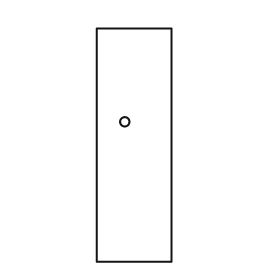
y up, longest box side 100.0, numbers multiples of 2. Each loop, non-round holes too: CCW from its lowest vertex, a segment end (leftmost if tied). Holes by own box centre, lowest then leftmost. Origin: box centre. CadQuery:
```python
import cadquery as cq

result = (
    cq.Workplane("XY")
    .moveTo(-16.0, -50.0)
    .lineTo(16.0, -50.0)
    .lineTo(16.0, 50.0)
    .lineTo(-16.0, 50.0)
    .close()
    .moveTo(-4.0, 10.0)
    .circle(2.0)
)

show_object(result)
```